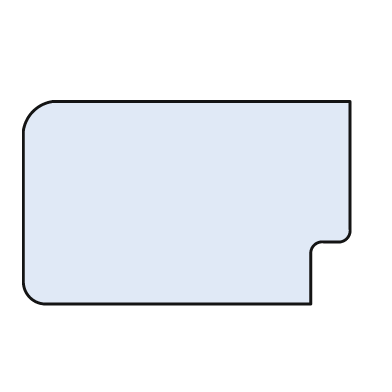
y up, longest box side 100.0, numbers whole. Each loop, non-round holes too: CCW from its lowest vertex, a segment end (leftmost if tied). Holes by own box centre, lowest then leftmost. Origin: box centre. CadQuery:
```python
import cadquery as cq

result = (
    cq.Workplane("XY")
    .moveTo(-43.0, -31.0)
    .lineTo(38.0, -31.0)
    .lineTo(38.0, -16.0)
    .threePointArc((39.0, -13.0), (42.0, -12.0))
    .lineTo(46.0, -12.0)
    .threePointArc((49.0, -11.0), (50.0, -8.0))
    .lineTo(50.0, 31.0)
    .lineTo(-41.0, 31.0)
    .threePointArc((-47.0, 28.0), (-50.0, 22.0))
    .lineTo(-50.0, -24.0)
    .threePointArc((-48.0, -29.0), (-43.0, -31.0))
    .close()
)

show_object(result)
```